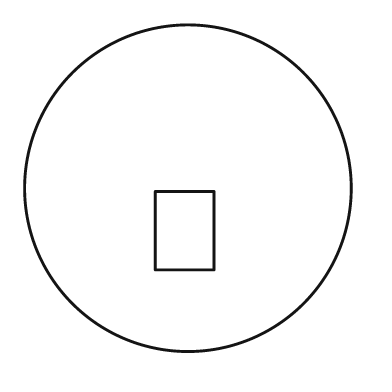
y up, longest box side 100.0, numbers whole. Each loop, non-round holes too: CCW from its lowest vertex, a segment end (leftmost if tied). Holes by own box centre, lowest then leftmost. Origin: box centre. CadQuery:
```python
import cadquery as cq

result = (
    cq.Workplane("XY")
    .moveTo(0.0, 0.0)
    .circle(50.0)
    .moveTo(-10.0, -25.0)
    .lineTo(8.0, -25.0)
    .lineTo(8.0, -1.0)
    .lineTo(-10.0, -1.0)
    .close()
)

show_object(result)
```